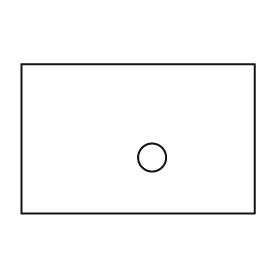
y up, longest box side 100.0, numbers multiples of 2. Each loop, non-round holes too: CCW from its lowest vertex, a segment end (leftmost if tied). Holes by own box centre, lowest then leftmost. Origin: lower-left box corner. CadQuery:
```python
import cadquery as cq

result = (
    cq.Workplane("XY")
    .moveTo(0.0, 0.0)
    .lineTo(100.0, 0.0)
    .lineTo(100.0, 64.0)
    .lineTo(0.0, 64.0)
    .close()
    .moveTo(56.0, 24.0)
    .circle(6.0)
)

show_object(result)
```